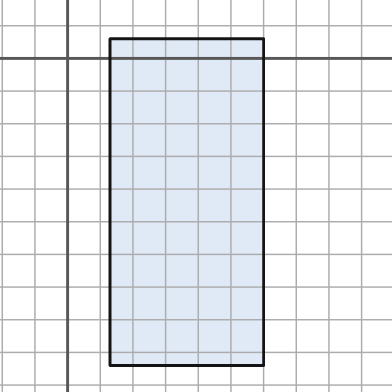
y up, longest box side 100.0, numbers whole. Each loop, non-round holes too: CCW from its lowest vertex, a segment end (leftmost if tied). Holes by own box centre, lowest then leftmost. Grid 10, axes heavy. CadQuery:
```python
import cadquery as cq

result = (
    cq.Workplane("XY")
    .moveTo(13.0, -94.0)
    .lineTo(60.0, -94.0)
    .lineTo(60.0, 6.0)
    .lineTo(13.0, 6.0)
    .close()
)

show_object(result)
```